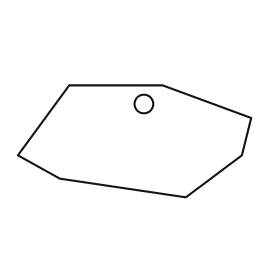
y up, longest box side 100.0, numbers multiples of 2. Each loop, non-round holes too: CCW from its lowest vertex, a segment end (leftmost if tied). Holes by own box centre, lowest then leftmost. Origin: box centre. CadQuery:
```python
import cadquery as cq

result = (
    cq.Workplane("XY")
    .moveTo(22.0, -24.0)
    .lineTo(46.0, -6.0)
    .lineTo(50.0, 10.0)
    .lineTo(12.0, 24.0)
    .lineTo(-28.0, 24.0)
    .lineTo(-50.0, -6.0)
    .lineTo(-32.0, -16.0)
    .close()
    .moveTo(4.0, 16.0)
    .circle(4.0)
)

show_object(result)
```